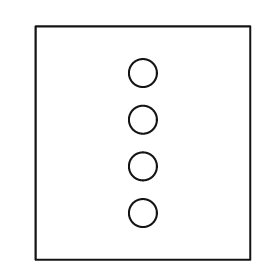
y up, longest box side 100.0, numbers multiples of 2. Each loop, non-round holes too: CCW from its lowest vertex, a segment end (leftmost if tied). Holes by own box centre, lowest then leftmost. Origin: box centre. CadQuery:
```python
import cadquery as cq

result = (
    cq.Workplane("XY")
    .moveTo(-46.0, -50.0)
    .lineTo(46.0, -50.0)
    .lineTo(46.0, 50.0)
    .lineTo(-46.0, 50.0)
    .close()
    .moveTo(0.0, -30.0)
    .circle(6.0)
    .moveTo(0.0, -10.0)
    .circle(6.0)
    .moveTo(0.0, 10.0)
    .circle(6.0)
    .moveTo(0.0, 30.0)
    .circle(6.0)
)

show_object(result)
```